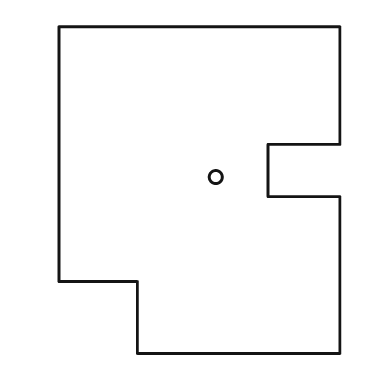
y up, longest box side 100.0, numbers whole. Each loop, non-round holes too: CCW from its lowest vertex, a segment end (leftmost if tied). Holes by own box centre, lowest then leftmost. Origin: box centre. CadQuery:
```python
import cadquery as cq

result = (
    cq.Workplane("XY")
    .moveTo(-19.0, -50.0)
    .lineTo(43.0, -50.0)
    .lineTo(43.0, -2.0)
    .lineTo(21.0, -2.0)
    .lineTo(21.0, 14.0)
    .lineTo(43.0, 14.0)
    .lineTo(43.0, 50.0)
    .lineTo(-43.0, 50.0)
    .lineTo(-43.0, -28.0)
    .lineTo(-19.0, -28.0)
    .close()
    .moveTo(5.0, 4.0)
    .circle(2.0)
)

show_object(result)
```